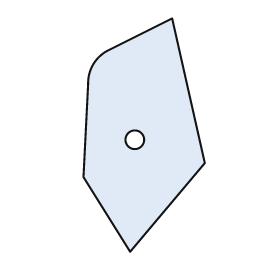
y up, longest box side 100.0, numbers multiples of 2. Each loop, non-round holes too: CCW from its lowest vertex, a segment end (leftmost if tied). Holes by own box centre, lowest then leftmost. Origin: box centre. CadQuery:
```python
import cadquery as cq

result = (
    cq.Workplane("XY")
    .moveTo(-6.0, -50.0)
    .lineTo(26.0, -12.0)
    .lineTo(12.0, 50.0)
    .lineTo(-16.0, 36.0)
    .threePointArc((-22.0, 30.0), (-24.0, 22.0))
    .lineTo(-26.0, -18.0)
    .close()
    .moveTo(-4.0, -2.0)
    .circle(4.0)
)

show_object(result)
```